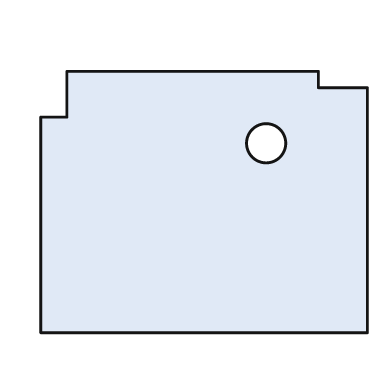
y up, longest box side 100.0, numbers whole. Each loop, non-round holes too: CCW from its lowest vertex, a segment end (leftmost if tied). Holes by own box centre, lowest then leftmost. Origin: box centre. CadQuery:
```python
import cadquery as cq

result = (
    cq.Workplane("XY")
    .moveTo(-50.0, -40.0)
    .lineTo(50.0, -40.0)
    .lineTo(50.0, 35.0)
    .lineTo(35.0, 35.0)
    .lineTo(35.0, 40.0)
    .lineTo(-42.0, 40.0)
    .lineTo(-42.0, 26.0)
    .lineTo(-50.0, 26.0)
    .close()
    .moveTo(19.0, 18.0)
    .circle(6.0)
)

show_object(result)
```